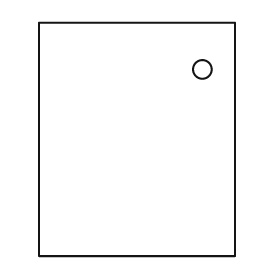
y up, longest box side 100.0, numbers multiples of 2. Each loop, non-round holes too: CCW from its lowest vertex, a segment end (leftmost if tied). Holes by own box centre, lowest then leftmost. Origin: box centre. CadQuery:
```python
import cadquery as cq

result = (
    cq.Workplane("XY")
    .moveTo(-42.0, -50.0)
    .lineTo(42.0, -50.0)
    .lineTo(42.0, 50.0)
    .lineTo(-42.0, 50.0)
    .close()
    .moveTo(28.0, 30.0)
    .circle(4.0)
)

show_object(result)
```